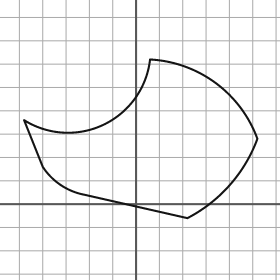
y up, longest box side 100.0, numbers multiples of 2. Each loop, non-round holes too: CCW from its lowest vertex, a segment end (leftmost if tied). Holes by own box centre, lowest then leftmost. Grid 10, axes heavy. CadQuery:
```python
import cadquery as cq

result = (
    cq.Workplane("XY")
    .moveTo(22.0, -6.0)
    .threePointArc((40.0, 8.0), (52.0, 28.0))
    .threePointArc((34.0, 52.0), (6.0, 62.0))
    .threePointArc((-14.0, 34.0), (-48.0, 36.0))
    .lineTo(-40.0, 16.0)
    .threePointArc((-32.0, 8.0), (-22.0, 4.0))
    .close()
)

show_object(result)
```